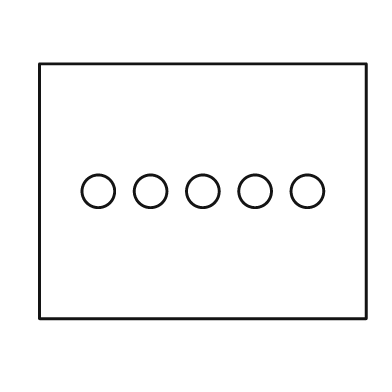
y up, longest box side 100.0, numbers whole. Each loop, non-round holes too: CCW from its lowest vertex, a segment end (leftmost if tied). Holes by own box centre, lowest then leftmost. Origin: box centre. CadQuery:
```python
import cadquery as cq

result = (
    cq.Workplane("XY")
    .moveTo(-50.0, -39.0)
    .lineTo(50.0, -39.0)
    .lineTo(50.0, 39.0)
    .lineTo(-50.0, 39.0)
    .close()
    .moveTo(-32.0, 0.0)
    .circle(5.0)
    .moveTo(-16.0, 0.0)
    .circle(5.0)
    .moveTo(0.0, 0.0)
    .circle(5.0)
    .moveTo(16.0, 0.0)
    .circle(5.0)
    .moveTo(32.0, 0.0)
    .circle(5.0)
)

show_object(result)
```